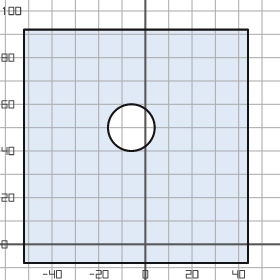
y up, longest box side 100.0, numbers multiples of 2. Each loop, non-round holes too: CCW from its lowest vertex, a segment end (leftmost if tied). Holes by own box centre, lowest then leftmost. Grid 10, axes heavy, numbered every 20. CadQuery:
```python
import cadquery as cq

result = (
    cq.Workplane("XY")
    .moveTo(-52.0, -8.0)
    .lineTo(44.0, -8.0)
    .lineTo(44.0, 92.0)
    .lineTo(-52.0, 92.0)
    .close()
    .moveTo(-6.0, 50.0)
    .circle(10.0)
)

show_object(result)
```